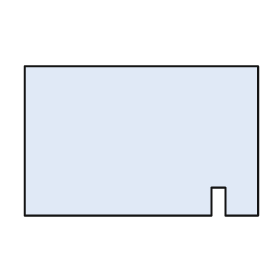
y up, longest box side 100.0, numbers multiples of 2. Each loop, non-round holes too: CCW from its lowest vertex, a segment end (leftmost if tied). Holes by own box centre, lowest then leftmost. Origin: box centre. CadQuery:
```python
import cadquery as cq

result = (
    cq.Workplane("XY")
    .moveTo(-50.0, -32.0)
    .lineTo(30.0, -32.0)
    .lineTo(30.0, -20.0)
    .lineTo(36.0, -20.0)
    .lineTo(36.0, -32.0)
    .lineTo(50.0, -32.0)
    .lineTo(50.0, 32.0)
    .lineTo(-50.0, 32.0)
    .close()
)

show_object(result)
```